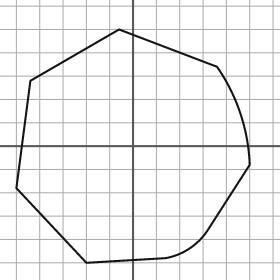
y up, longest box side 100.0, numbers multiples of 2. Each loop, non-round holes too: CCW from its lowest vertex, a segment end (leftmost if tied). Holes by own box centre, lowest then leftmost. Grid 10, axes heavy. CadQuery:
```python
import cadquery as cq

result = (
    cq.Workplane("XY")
    .moveTo(-20.0, -50.0)
    .lineTo(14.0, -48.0)
    .threePointArc((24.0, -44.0), (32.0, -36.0))
    .lineTo(50.0, -8.0)
    .threePointArc((46.0, 14.0), (36.0, 34.0))
    .lineTo(-6.0, 50.0)
    .lineTo(-44.0, 28.0)
    .lineTo(-50.0, -18.0)
    .close()
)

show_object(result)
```